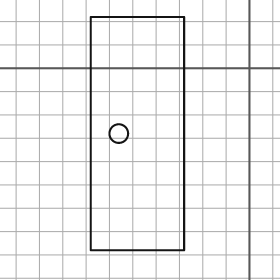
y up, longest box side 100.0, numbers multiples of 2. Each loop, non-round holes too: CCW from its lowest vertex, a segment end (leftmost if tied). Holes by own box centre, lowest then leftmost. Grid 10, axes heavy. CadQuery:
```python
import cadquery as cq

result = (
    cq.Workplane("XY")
    .moveTo(-68.0, -78.0)
    .lineTo(-28.0, -78.0)
    .lineTo(-28.0, 22.0)
    .lineTo(-68.0, 22.0)
    .close()
    .moveTo(-56.0, -28.0)
    .circle(4.0)
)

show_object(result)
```